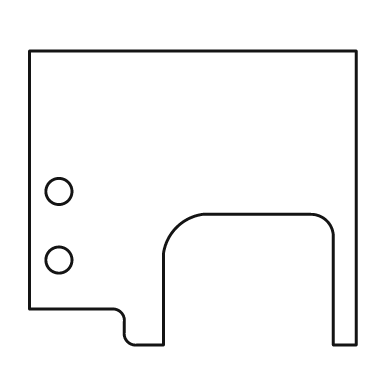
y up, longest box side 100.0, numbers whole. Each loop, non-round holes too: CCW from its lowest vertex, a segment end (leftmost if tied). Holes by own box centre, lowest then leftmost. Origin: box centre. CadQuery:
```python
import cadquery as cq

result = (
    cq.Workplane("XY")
    .moveTo(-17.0, -45.0)
    .lineTo(-9.0, -45.0)
    .lineTo(-9.0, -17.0)
    .threePointArc((-5.0, -9.0), (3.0, -5.0))
    .lineTo(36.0, -5.0)
    .threePointArc((41.0, -7.0), (43.0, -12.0))
    .lineTo(43.0, -45.0)
    .lineTo(50.0, -45.0)
    .lineTo(50.0, 45.0)
    .lineTo(-50.0, 45.0)
    .lineTo(-50.0, -34.0)
    .lineTo(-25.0, -34.0)
    .threePointArc((-22.0, -35.0), (-21.0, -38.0))
    .lineTo(-21.0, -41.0)
    .threePointArc((-20.0, -44.0), (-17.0, -45.0))
    .close()
    .moveTo(-41.0, -19.0)
    .circle(4.0)
    .moveTo(-41.0, 2.0)
    .circle(4.0)
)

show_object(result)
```